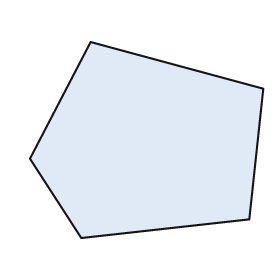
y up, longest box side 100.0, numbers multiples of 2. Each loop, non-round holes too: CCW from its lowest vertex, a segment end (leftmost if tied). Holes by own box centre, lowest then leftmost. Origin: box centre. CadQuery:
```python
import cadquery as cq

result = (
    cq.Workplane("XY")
    .moveTo(-28.0, -42.0)
    .lineTo(44.0, -34.0)
    .lineTo(50.0, 22.0)
    .lineTo(-24.0, 42.0)
    .lineTo(-50.0, -8.0)
    .close()
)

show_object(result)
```